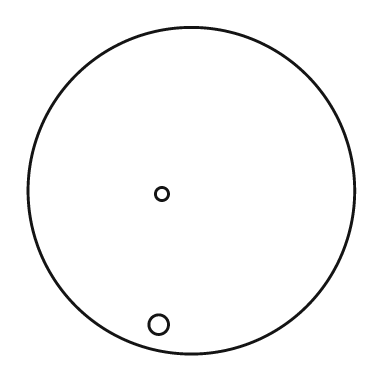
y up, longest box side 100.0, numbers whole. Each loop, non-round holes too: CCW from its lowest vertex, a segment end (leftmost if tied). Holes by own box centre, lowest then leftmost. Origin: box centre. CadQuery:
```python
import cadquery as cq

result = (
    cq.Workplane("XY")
    .moveTo(0.0, 0.0)
    .circle(50.0)
    .moveTo(-10.0, -41.0)
    .circle(3.0)
    .moveTo(-9.0, -1.0)
    .circle(2.0)
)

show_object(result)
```